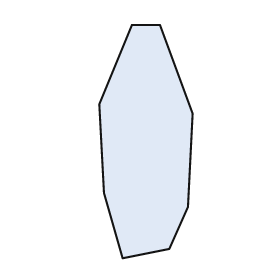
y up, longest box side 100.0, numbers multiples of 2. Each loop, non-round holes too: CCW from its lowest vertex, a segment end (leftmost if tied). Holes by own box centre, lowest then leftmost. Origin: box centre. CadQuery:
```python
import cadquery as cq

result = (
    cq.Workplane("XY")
    .moveTo(-10.0, -50.0)
    .lineTo(10.0, -46.0)
    .lineTo(18.0, -28.0)
    .lineTo(20.0, 12.0)
    .lineTo(6.0, 50.0)
    .lineTo(-6.0, 50.0)
    .lineTo(-20.0, 16.0)
    .lineTo(-18.0, -22.0)
    .close()
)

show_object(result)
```